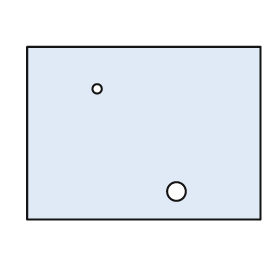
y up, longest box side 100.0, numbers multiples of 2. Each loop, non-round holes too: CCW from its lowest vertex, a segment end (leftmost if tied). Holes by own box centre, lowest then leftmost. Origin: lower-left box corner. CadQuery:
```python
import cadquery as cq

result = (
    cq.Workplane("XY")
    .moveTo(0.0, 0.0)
    .lineTo(100.0, 0.0)
    .lineTo(100.0, 74.0)
    .lineTo(0.0, 74.0)
    .close()
    .moveTo(64.0, 12.0)
    .circle(4.0)
    .moveTo(30.0, 56.0)
    .circle(2.0)
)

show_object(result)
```